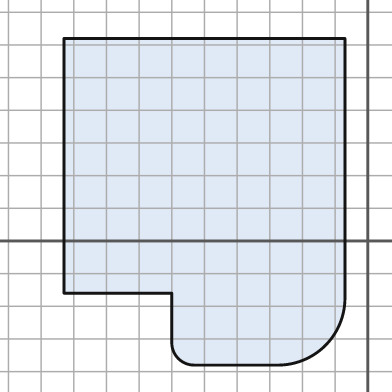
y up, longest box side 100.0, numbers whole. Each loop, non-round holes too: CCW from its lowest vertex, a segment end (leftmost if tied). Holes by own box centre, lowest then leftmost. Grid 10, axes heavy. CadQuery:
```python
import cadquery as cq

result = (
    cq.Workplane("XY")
    .moveTo(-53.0, -38.0)
    .lineTo(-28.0, -38.0)
    .threePointArc((-13.0, -32.0), (-7.0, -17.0))
    .lineTo(-7.0, 62.0)
    .lineTo(-93.0, 62.0)
    .lineTo(-93.0, -16.0)
    .lineTo(-60.0, -16.0)
    .lineTo(-60.0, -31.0)
    .threePointArc((-58.0, -36.0), (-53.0, -38.0))
    .close()
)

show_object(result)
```